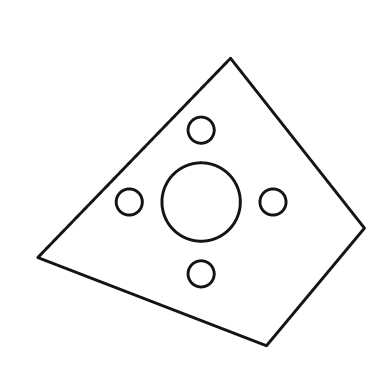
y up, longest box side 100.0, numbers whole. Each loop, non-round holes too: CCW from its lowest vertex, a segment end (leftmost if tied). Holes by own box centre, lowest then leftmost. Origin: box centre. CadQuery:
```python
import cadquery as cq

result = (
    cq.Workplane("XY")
    .moveTo(20.0, -44.0)
    .lineTo(50.0, -8.0)
    .lineTo(9.0, 44.0)
    .lineTo(-50.0, -17.0)
    .close()
    .moveTo(0.0, -22.0)
    .circle(4.0)
    .moveTo(-22.0, 0.0)
    .circle(4.0)
    .moveTo(0.0, 0.0)
    .circle(12.0)
    .moveTo(22.0, 0.0)
    .circle(4.0)
    .moveTo(0.0, 22.0)
    .circle(4.0)
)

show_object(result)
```